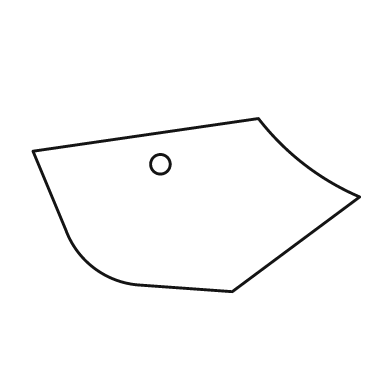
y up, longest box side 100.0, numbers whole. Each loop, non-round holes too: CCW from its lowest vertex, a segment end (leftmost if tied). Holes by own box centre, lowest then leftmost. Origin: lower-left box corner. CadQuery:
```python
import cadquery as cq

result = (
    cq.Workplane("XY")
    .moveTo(61.0, 0.0)
    .lineTo(100.0, 29.0)
    .threePointArc((83.0, 39.0), (69.0, 53.0))
    .lineTo(0.0, 43.0)
    .lineTo(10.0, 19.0)
    .threePointArc((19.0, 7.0), (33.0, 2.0))
    .close()
    .moveTo(39.0, 39.0)
    .circle(3.0)
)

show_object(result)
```